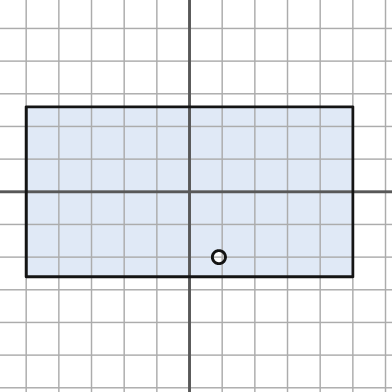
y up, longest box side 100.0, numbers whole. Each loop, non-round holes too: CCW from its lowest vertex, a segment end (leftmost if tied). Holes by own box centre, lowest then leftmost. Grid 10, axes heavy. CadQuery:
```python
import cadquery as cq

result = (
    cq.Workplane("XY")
    .moveTo(-50.0, -26.0)
    .lineTo(50.0, -26.0)
    .lineTo(50.0, 26.0)
    .lineTo(-50.0, 26.0)
    .close()
    .moveTo(9.0, -20.0)
    .circle(2.0)
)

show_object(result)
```